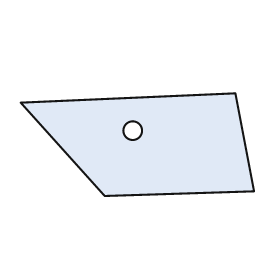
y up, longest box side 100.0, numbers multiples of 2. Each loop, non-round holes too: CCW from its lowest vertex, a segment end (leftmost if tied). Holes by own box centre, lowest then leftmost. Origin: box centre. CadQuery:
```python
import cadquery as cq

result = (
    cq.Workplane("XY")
    .moveTo(-14.0, -22.0)
    .lineTo(50.0, -20.0)
    .lineTo(42.0, 22.0)
    .lineTo(-50.0, 18.0)
    .close()
    .moveTo(-2.0, 6.0)
    .circle(4.0)
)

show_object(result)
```